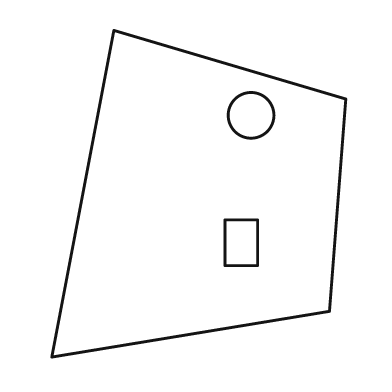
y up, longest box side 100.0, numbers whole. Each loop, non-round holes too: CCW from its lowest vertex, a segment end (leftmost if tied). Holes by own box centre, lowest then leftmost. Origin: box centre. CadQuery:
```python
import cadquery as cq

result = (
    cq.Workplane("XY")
    .moveTo(-45.0, -50.0)
    .lineTo(40.0, -36.0)
    .lineTo(45.0, 29.0)
    .lineTo(-26.0, 50.0)
    .close()
    .moveTo(8.0, -22.0)
    .lineTo(18.0, -22.0)
    .lineTo(18.0, -8.0)
    .lineTo(8.0, -8.0)
    .close()
    .moveTo(16.0, 24.0)
    .circle(7.0)
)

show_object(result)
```